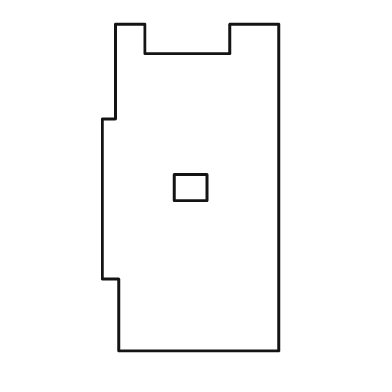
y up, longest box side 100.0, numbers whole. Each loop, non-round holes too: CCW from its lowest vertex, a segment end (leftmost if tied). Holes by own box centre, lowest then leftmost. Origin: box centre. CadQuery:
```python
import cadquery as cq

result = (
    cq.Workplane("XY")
    .moveTo(-22.0, -50.0)
    .lineTo(27.0, -50.0)
    .lineTo(27.0, 50.0)
    .lineTo(12.0, 50.0)
    .lineTo(12.0, 41.0)
    .lineTo(-14.0, 41.0)
    .lineTo(-14.0, 50.0)
    .lineTo(-23.0, 50.0)
    .lineTo(-23.0, 21.0)
    .lineTo(-27.0, 21.0)
    .lineTo(-27.0, -28.0)
    .lineTo(-22.0, -28.0)
    .close()
    .moveTo(-5.0, -4.0)
    .lineTo(5.0, -4.0)
    .lineTo(5.0, 4.0)
    .lineTo(-5.0, 4.0)
    .close()
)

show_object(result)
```